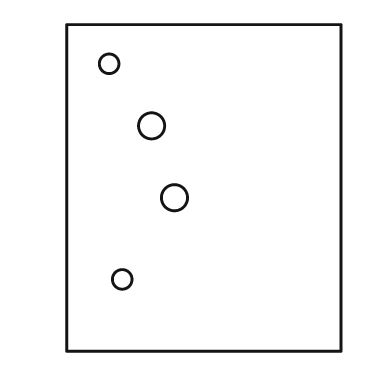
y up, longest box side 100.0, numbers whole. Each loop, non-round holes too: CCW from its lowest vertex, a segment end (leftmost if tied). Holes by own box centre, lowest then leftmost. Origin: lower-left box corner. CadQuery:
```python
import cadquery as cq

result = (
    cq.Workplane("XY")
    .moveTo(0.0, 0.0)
    .lineTo(84.0, 0.0)
    .lineTo(84.0, 100.0)
    .lineTo(0.0, 100.0)
    .close()
    .moveTo(17.0, 22.0)
    .circle(3.0)
    .moveTo(33.0, 47.0)
    .circle(4.0)
    .moveTo(26.0, 69.0)
    .circle(4.0)
    .moveTo(13.0, 88.0)
    .circle(3.0)
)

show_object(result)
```